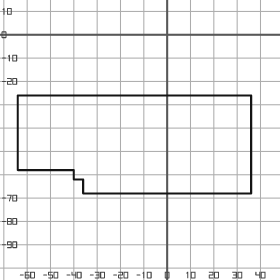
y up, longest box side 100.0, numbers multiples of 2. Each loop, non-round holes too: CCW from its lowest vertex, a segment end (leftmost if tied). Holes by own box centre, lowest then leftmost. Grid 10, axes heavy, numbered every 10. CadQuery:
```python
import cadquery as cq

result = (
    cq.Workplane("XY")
    .moveTo(-36.0, -68.0)
    .lineTo(36.0, -68.0)
    .lineTo(36.0, -26.0)
    .lineTo(-64.0, -26.0)
    .lineTo(-64.0, -58.0)
    .lineTo(-40.0, -58.0)
    .lineTo(-40.0, -62.0)
    .lineTo(-36.0, -62.0)
    .close()
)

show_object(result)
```